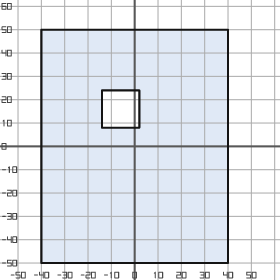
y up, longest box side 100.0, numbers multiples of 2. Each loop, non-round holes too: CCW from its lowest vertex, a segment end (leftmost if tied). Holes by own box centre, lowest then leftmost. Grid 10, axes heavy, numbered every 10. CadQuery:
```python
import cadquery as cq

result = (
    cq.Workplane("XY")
    .moveTo(-40.0, -50.0)
    .lineTo(40.0, -50.0)
    .lineTo(40.0, 50.0)
    .lineTo(-40.0, 50.0)
    .close()
    .moveTo(-14.0, 8.0)
    .lineTo(2.0, 8.0)
    .lineTo(2.0, 24.0)
    .lineTo(-14.0, 24.0)
    .close()
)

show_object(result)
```